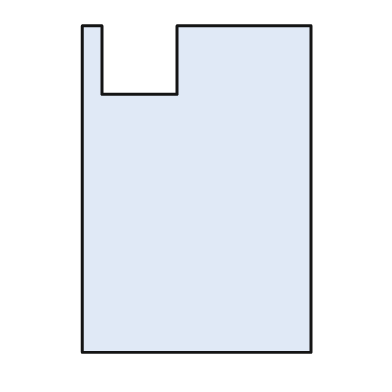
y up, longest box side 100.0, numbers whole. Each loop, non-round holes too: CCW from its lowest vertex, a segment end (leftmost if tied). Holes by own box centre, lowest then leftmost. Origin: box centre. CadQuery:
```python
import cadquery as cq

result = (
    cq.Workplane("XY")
    .moveTo(-35.0, -50.0)
    .lineTo(35.0, -50.0)
    .lineTo(35.0, 50.0)
    .lineTo(-6.0, 50.0)
    .lineTo(-6.0, 29.0)
    .lineTo(-29.0, 29.0)
    .lineTo(-29.0, 50.0)
    .lineTo(-35.0, 50.0)
    .close()
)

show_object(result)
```